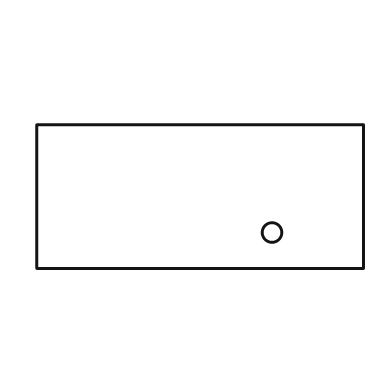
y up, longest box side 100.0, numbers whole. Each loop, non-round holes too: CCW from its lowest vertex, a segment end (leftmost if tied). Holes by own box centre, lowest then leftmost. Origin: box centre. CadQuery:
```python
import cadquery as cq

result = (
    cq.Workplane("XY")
    .moveTo(-50.0, -22.0)
    .lineTo(50.0, -22.0)
    .lineTo(50.0, 22.0)
    .lineTo(-50.0, 22.0)
    .close()
    .moveTo(22.0, -11.0)
    .circle(3.0)
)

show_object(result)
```